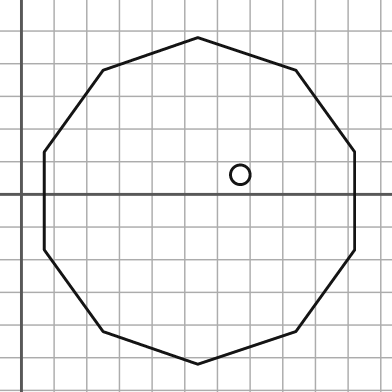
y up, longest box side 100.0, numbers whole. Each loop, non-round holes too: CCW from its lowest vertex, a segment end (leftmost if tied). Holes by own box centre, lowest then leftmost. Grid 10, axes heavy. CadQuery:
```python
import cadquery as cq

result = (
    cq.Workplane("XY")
    .moveTo(54.0, -52.0)
    .lineTo(84.0, -42.0)
    .lineTo(102.0, -17.0)
    .lineTo(102.0, 13.0)
    .lineTo(84.0, 38.0)
    .lineTo(54.0, 48.0)
    .lineTo(25.0, 38.0)
    .lineTo(7.0, 13.0)
    .lineTo(7.0, -17.0)
    .lineTo(25.0, -42.0)
    .close()
    .moveTo(67.0, 6.0)
    .circle(3.0)
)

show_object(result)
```